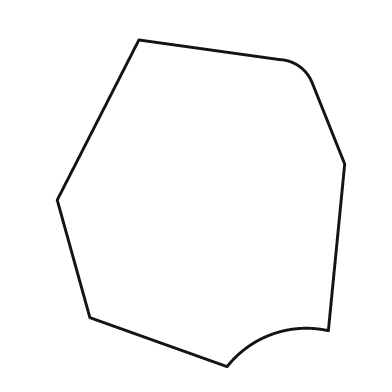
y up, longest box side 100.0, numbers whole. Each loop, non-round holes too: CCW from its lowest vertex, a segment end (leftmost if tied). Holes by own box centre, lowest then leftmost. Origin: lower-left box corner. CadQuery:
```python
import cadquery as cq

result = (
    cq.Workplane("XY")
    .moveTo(52.0, 0.0)
    .threePointArc((66.0, 10.0), (83.0, 11.0))
    .lineTo(88.0, 62.0)
    .lineTo(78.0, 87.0)
    .threePointArc((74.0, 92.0), (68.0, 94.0))
    .lineTo(25.0, 100.0)
    .lineTo(0.0, 51.0)
    .lineTo(10.0, 15.0)
    .close()
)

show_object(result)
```